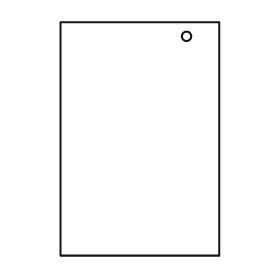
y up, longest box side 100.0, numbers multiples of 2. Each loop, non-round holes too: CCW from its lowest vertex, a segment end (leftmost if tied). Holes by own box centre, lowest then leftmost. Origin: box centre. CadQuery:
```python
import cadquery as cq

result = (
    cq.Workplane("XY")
    .moveTo(-34.0, -50.0)
    .lineTo(34.0, -50.0)
    .lineTo(34.0, 50.0)
    .lineTo(-34.0, 50.0)
    .close()
    .moveTo(20.0, 44.0)
    .circle(2.0)
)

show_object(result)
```